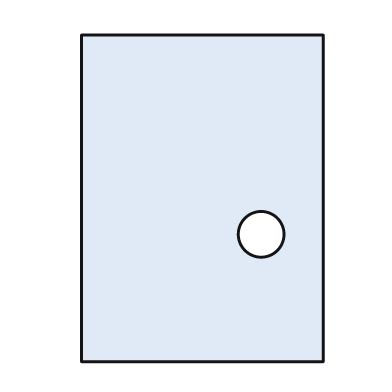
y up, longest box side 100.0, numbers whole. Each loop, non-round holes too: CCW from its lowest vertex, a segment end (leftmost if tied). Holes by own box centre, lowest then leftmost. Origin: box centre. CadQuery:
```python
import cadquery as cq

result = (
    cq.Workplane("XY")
    .moveTo(-37.0, -50.0)
    .lineTo(37.0, -50.0)
    .lineTo(37.0, 50.0)
    .lineTo(-37.0, 50.0)
    .close()
    .moveTo(18.0, -11.0)
    .circle(7.0)
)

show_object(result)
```